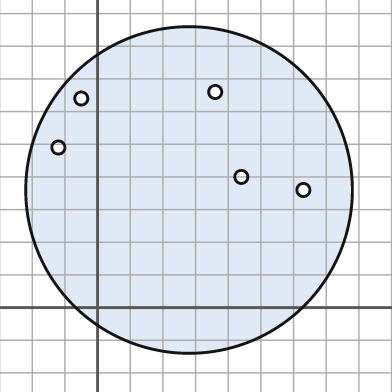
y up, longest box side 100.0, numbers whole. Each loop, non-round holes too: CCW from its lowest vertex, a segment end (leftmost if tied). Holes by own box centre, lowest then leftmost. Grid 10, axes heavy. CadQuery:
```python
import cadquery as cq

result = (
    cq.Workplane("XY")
    .moveTo(28.0, 36.0)
    .circle(50.0)
    .moveTo(63.0, 36.0)
    .circle(2.0)
    .moveTo(44.0, 40.0)
    .circle(2.0)
    .moveTo(-12.0, 49.0)
    .circle(2.0)
    .moveTo(-5.0, 64.0)
    .circle(2.0)
    .moveTo(36.0, 66.0)
    .circle(2.0)
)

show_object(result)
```